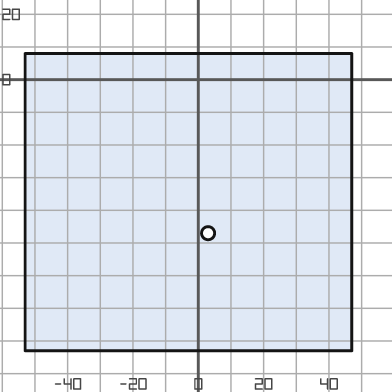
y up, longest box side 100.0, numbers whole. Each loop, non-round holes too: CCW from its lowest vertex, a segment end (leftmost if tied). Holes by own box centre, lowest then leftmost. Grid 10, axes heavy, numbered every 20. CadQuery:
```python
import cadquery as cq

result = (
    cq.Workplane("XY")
    .moveTo(-53.0, -83.0)
    .lineTo(47.0, -83.0)
    .lineTo(47.0, 8.0)
    .lineTo(-53.0, 8.0)
    .close()
    .moveTo(3.0, -47.0)
    .circle(2.0)
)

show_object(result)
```